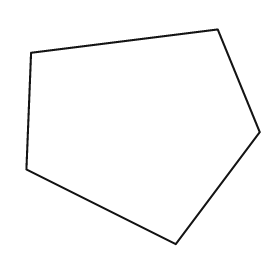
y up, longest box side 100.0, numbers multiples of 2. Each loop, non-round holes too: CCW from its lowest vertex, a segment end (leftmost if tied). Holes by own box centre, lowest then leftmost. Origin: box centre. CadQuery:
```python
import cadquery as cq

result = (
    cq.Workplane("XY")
    .moveTo(14.0, -46.0)
    .lineTo(50.0, 2.0)
    .lineTo(32.0, 46.0)
    .lineTo(-48.0, 36.0)
    .lineTo(-50.0, -14.0)
    .close()
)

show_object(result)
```